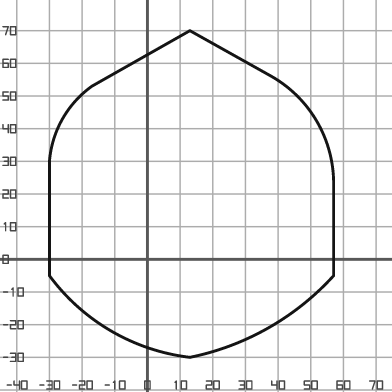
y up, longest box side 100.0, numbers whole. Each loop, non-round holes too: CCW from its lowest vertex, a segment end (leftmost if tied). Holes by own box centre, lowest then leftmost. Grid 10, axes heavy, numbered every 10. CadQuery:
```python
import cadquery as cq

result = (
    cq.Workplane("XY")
    .moveTo(13.0, -30.0)
    .threePointArc((37.0, -21.0), (57.0, -5.0))
    .lineTo(57.0, 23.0)
    .threePointArc((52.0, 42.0), (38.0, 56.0))
    .lineTo(13.0, 70.0)
    .lineTo(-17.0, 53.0)
    .threePointArc((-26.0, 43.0), (-30.0, 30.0))
    .lineTo(-30.0, -5.0)
    .threePointArc((-11.0, -22.0), (13.0, -30.0))
    .close()
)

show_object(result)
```